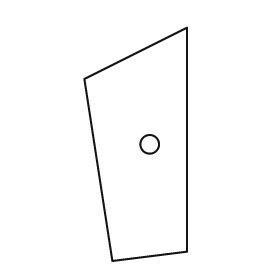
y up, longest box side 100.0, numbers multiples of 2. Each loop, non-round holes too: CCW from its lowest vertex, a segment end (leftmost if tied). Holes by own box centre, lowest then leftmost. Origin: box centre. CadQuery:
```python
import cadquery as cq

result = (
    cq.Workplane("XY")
    .moveTo(-10.0, -50.0)
    .lineTo(22.0, -46.0)
    .lineTo(22.0, 50.0)
    .lineTo(-22.0, 28.0)
    .close()
    .moveTo(6.0, 0.0)
    .circle(4.0)
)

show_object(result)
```